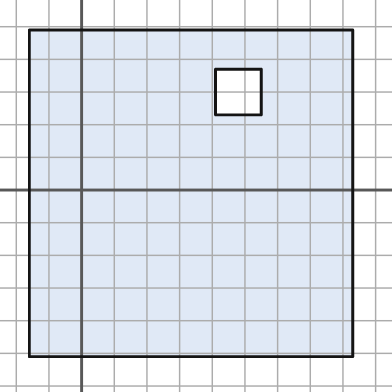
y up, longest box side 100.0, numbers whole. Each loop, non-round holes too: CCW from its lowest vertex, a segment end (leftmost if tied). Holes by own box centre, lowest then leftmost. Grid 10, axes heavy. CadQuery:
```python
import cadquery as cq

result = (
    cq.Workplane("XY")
    .moveTo(-16.0, -51.0)
    .lineTo(83.0, -51.0)
    .lineTo(83.0, 49.0)
    .lineTo(-16.0, 49.0)
    .close()
    .moveTo(41.0, 23.0)
    .lineTo(55.0, 23.0)
    .lineTo(55.0, 37.0)
    .lineTo(41.0, 37.0)
    .close()
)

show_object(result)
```